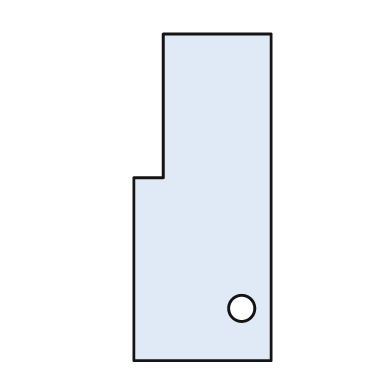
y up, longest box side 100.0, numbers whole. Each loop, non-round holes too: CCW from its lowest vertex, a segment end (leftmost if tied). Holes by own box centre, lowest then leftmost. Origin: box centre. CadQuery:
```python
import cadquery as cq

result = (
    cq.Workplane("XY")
    .moveTo(-21.0, -50.0)
    .lineTo(21.0, -50.0)
    .lineTo(21.0, 50.0)
    .lineTo(-12.0, 50.0)
    .lineTo(-12.0, 6.0)
    .lineTo(-21.0, 6.0)
    .close()
    .moveTo(12.0, -34.0)
    .circle(4.0)
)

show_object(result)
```